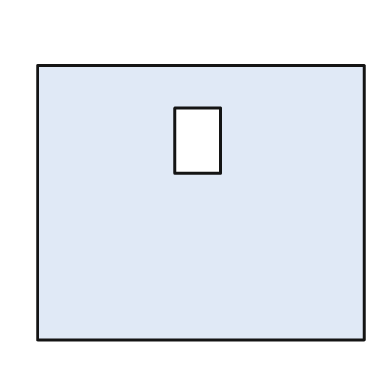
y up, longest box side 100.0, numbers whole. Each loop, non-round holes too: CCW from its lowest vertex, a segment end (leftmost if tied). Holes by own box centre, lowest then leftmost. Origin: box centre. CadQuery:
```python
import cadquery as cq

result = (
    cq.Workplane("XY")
    .moveTo(-50.0, -42.0)
    .lineTo(50.0, -42.0)
    .lineTo(50.0, 42.0)
    .lineTo(-50.0, 42.0)
    .close()
    .moveTo(-8.0, 9.0)
    .lineTo(6.0, 9.0)
    .lineTo(6.0, 29.0)
    .lineTo(-8.0, 29.0)
    .close()
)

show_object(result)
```